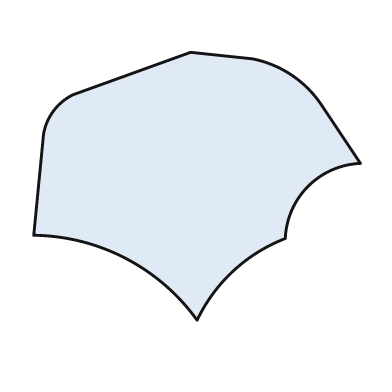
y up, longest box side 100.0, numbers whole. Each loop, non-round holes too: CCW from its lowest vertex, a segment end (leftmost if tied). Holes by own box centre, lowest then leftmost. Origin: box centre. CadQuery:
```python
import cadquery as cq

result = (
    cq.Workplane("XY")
    .moveTo(0.0, -41.0)
    .threePointArc((11.0, -26.0), (27.0, -16.0))
    .threePointArc((34.0, 0.0), (50.0, 7.0))
    .lineTo(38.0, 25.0)
    .threePointArc((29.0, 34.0), (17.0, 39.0))
    .lineTo(-2.0, 41.0)
    .lineTo(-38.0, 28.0)
    .threePointArc((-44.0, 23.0), (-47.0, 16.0))
    .lineTo(-50.0, -15.0)
    .threePointArc((-22.0, -22.0), (0.0, -41.0))
    .close()
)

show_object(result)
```